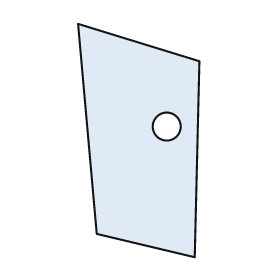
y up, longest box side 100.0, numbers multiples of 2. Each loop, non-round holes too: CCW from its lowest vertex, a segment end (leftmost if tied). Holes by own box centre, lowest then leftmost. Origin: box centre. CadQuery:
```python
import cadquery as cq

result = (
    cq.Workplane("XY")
    .moveTo(24.0, -50.0)
    .lineTo(26.0, 34.0)
    .lineTo(-26.0, 50.0)
    .lineTo(-18.0, -40.0)
    .close()
    .moveTo(12.0, 6.0)
    .circle(6.0)
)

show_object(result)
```